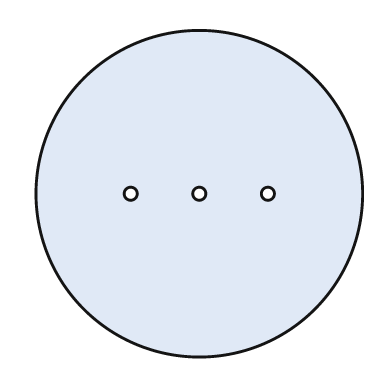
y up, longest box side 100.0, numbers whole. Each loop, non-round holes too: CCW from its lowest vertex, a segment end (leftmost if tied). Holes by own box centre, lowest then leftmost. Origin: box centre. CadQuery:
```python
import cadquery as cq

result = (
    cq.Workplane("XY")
    .moveTo(0.0, 0.0)
    .circle(50.0)
    .moveTo(-21.0, 0.0)
    .circle(2.0)
    .moveTo(0.0, 0.0)
    .circle(2.0)
    .moveTo(21.0, 0.0)
    .circle(2.0)
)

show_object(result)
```